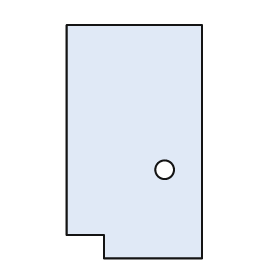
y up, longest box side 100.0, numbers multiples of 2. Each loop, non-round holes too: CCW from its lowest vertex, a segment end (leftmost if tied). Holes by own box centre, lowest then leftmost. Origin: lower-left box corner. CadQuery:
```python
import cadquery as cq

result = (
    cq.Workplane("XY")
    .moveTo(16.0, 0.0)
    .lineTo(58.0, 0.0)
    .lineTo(58.0, 100.0)
    .lineTo(0.0, 100.0)
    .lineTo(0.0, 10.0)
    .lineTo(16.0, 10.0)
    .close()
    .moveTo(42.0, 38.0)
    .circle(4.0)
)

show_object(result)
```